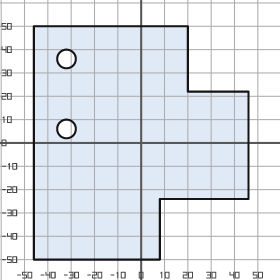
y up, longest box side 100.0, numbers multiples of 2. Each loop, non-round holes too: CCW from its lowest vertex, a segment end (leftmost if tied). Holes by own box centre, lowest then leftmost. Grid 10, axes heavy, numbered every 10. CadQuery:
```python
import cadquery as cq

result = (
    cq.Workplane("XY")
    .moveTo(-46.0, -50.0)
    .lineTo(8.0, -50.0)
    .lineTo(8.0, -24.0)
    .lineTo(46.0, -24.0)
    .lineTo(46.0, 22.0)
    .lineTo(20.0, 22.0)
    .lineTo(20.0, 50.0)
    .lineTo(-46.0, 50.0)
    .close()
    .moveTo(-32.0, 6.0)
    .circle(4.0)
    .moveTo(-32.0, 36.0)
    .circle(4.0)
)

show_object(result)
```